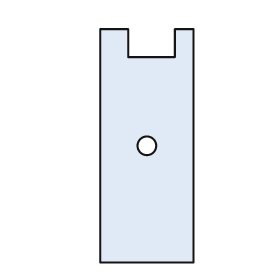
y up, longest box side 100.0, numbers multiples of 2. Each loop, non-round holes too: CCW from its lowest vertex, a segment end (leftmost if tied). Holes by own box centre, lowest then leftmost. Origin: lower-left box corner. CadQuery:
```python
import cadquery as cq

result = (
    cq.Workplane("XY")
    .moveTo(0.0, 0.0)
    .lineTo(40.0, 0.0)
    .lineTo(40.0, 100.0)
    .lineTo(32.0, 100.0)
    .lineTo(32.0, 88.0)
    .lineTo(12.0, 88.0)
    .lineTo(12.0, 100.0)
    .lineTo(0.0, 100.0)
    .close()
    .moveTo(20.0, 50.0)
    .circle(4.0)
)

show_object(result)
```